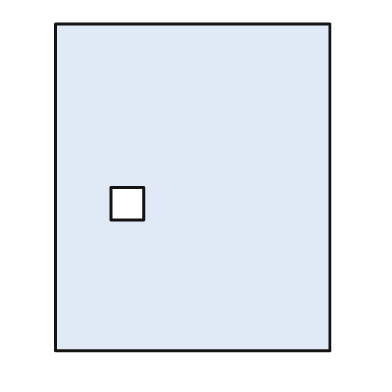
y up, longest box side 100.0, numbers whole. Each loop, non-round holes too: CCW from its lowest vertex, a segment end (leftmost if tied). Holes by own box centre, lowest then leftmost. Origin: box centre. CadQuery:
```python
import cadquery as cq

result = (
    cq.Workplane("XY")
    .moveTo(-42.0, -50.0)
    .lineTo(42.0, -50.0)
    .lineTo(42.0, 50.0)
    .lineTo(-42.0, 50.0)
    .close()
    .moveTo(-25.0, -10.0)
    .lineTo(-15.0, -10.0)
    .lineTo(-15.0, 0.0)
    .lineTo(-25.0, 0.0)
    .close()
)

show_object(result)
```